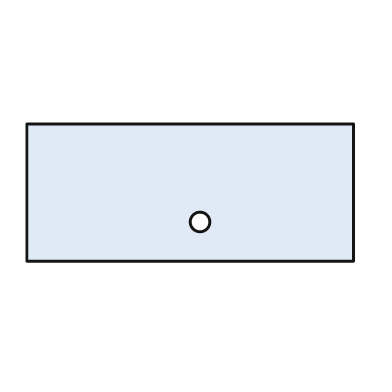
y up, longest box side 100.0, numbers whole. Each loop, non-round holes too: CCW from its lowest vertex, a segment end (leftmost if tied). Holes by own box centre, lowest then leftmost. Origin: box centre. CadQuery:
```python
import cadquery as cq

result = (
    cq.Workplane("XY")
    .moveTo(-50.0, -21.0)
    .lineTo(50.0, -21.0)
    .lineTo(50.0, 21.0)
    .lineTo(-50.0, 21.0)
    .close()
    .moveTo(3.0, -9.0)
    .circle(3.0)
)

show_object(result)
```